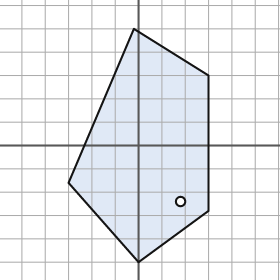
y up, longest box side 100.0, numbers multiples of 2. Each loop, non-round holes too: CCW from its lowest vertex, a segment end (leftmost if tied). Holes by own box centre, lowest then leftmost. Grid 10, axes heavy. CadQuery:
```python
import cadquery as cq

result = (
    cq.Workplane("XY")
    .moveTo(0.0, -50.0)
    .lineTo(30.0, -28.0)
    .lineTo(30.0, 30.0)
    .lineTo(-2.0, 50.0)
    .lineTo(-30.0, -16.0)
    .close()
    .moveTo(18.0, -24.0)
    .circle(2.0)
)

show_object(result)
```